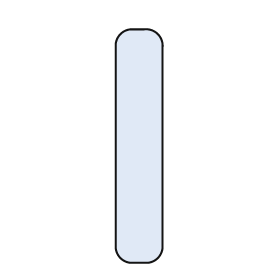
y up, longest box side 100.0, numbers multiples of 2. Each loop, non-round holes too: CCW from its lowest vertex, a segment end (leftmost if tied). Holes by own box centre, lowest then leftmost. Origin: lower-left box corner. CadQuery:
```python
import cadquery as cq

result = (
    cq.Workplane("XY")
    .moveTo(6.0, 0.0)
    .lineTo(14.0, 0.0)
    .threePointArc((18.0, 2.0), (20.0, 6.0))
    .lineTo(20.0, 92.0)
    .threePointArc((18.0, 98.0), (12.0, 100.0))
    .lineTo(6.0, 100.0)
    .threePointArc((2.0, 98.0), (0.0, 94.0))
    .lineTo(0.0, 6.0)
    .threePointArc((2.0, 2.0), (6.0, 0.0))
    .close()
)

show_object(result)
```